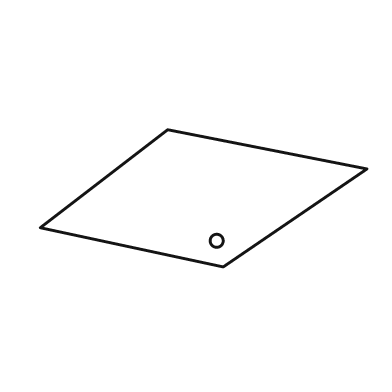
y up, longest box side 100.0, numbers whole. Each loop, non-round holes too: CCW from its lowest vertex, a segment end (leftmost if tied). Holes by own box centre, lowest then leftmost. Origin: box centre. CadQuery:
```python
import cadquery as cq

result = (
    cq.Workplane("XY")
    .moveTo(6.0, -21.0)
    .lineTo(50.0, 9.0)
    .lineTo(-11.0, 21.0)
    .lineTo(-50.0, -9.0)
    .close()
    .moveTo(4.0, -13.0)
    .circle(2.0)
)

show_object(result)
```